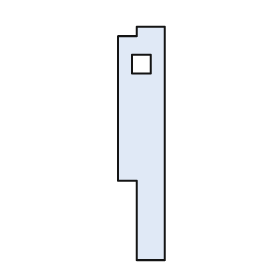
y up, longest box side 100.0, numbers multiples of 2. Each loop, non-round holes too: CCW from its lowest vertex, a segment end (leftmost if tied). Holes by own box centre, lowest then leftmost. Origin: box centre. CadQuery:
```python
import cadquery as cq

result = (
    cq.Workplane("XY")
    .moveTo(-2.0, -50.0)
    .lineTo(10.0, -50.0)
    .lineTo(10.0, 50.0)
    .lineTo(-2.0, 50.0)
    .lineTo(-2.0, 46.0)
    .lineTo(-10.0, 46.0)
    .lineTo(-10.0, -16.0)
    .lineTo(-2.0, -16.0)
    .close()
    .moveTo(-4.0, 30.0)
    .lineTo(4.0, 30.0)
    .lineTo(4.0, 38.0)
    .lineTo(-4.0, 38.0)
    .close()
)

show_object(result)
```